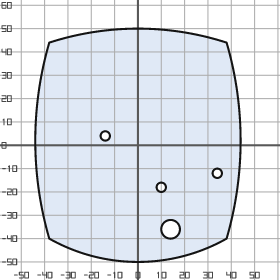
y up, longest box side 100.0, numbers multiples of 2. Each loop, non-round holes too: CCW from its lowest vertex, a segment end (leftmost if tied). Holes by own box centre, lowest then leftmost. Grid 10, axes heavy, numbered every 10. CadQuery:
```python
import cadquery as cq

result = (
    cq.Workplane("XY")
    .moveTo(-38.0, -40.0)
    .threePointArc((0.0, -50.0), (38.0, -40.0))
    .threePointArc((44.0, 2.0), (38.0, 44.0))
    .threePointArc((0.0, 50.0), (-38.0, 44.0))
    .threePointArc((-44.0, 2.0), (-38.0, -40.0))
    .close()
    .moveTo(14.0, -36.0)
    .circle(4.0)
    .moveTo(10.0, -18.0)
    .circle(2.0)
    .moveTo(34.0, -12.0)
    .circle(2.0)
    .moveTo(-14.0, 4.0)
    .circle(2.0)
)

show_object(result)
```